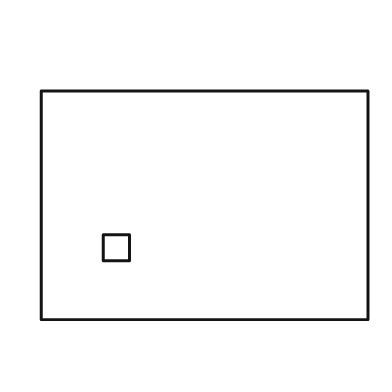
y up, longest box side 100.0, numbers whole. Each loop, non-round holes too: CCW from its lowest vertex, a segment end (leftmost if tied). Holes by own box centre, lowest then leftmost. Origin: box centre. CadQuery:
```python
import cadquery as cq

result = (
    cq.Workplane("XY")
    .moveTo(-50.0, -35.0)
    .lineTo(50.0, -35.0)
    .lineTo(50.0, 35.0)
    .lineTo(-50.0, 35.0)
    .close()
    .moveTo(-31.0, -17.0)
    .lineTo(-23.0, -17.0)
    .lineTo(-23.0, -9.0)
    .lineTo(-31.0, -9.0)
    .close()
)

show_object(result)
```